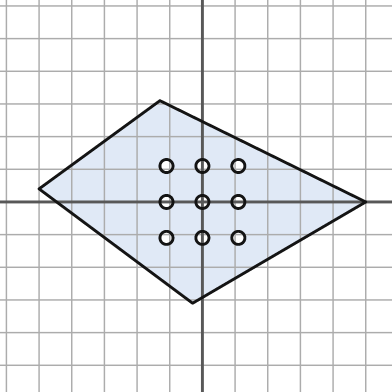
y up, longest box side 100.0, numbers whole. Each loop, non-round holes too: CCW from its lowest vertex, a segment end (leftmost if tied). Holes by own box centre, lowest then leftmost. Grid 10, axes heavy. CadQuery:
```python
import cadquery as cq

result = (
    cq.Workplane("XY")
    .moveTo(-3.0, -31.0)
    .lineTo(50.0, 0.0)
    .lineTo(-13.0, 31.0)
    .lineTo(-50.0, 4.0)
    .close()
    .moveTo(-11.0, -11.0)
    .circle(2.0)
    .moveTo(0.0, -11.0)
    .circle(2.0)
    .moveTo(11.0, -11.0)
    .circle(2.0)
    .moveTo(-11.0, 0.0)
    .circle(2.0)
    .moveTo(0.0, 0.0)
    .circle(2.0)
    .moveTo(11.0, 0.0)
    .circle(2.0)
    .moveTo(-11.0, 11.0)
    .circle(2.0)
    .moveTo(0.0, 11.0)
    .circle(2.0)
    .moveTo(11.0, 11.0)
    .circle(2.0)
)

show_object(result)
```